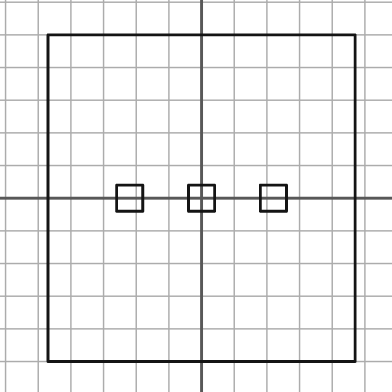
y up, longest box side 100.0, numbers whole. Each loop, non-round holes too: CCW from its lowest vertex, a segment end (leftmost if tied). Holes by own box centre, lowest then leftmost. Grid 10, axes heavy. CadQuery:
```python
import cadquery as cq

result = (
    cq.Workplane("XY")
    .moveTo(-47.0, -50.0)
    .lineTo(47.0, -50.0)
    .lineTo(47.0, 50.0)
    .lineTo(-47.0, 50.0)
    .close()
    .moveTo(-26.0, -4.0)
    .lineTo(-18.0, -4.0)
    .lineTo(-18.0, 4.0)
    .lineTo(-26.0, 4.0)
    .close()
    .moveTo(-4.0, -4.0)
    .lineTo(4.0, -4.0)
    .lineTo(4.0, 4.0)
    .lineTo(-4.0, 4.0)
    .close()
    .moveTo(18.0, -4.0)
    .lineTo(26.0, -4.0)
    .lineTo(26.0, 4.0)
    .lineTo(18.0, 4.0)
    .close()
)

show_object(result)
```